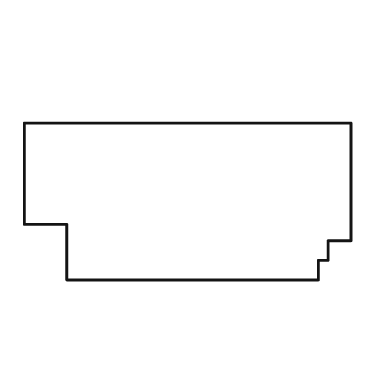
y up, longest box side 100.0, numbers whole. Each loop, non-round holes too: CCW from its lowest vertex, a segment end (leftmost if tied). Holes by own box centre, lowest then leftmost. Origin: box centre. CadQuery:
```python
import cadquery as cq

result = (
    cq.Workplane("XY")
    .moveTo(-37.0, -24.0)
    .lineTo(40.0, -24.0)
    .lineTo(40.0, -18.0)
    .lineTo(43.0, -18.0)
    .lineTo(43.0, -12.0)
    .lineTo(50.0, -12.0)
    .lineTo(50.0, 24.0)
    .lineTo(-50.0, 24.0)
    .lineTo(-50.0, -7.0)
    .lineTo(-37.0, -7.0)
    .close()
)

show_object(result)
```